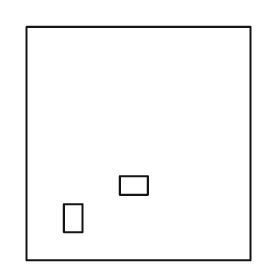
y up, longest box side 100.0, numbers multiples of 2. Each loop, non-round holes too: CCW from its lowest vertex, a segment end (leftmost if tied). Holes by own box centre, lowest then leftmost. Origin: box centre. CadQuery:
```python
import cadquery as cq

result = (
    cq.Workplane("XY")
    .moveTo(-48.0, -50.0)
    .lineTo(48.0, -50.0)
    .lineTo(48.0, 50.0)
    .lineTo(-48.0, 50.0)
    .close()
    .moveTo(-32.0, -38.0)
    .lineTo(-24.0, -38.0)
    .lineTo(-24.0, -26.0)
    .lineTo(-32.0, -26.0)
    .close()
    .moveTo(-8.0, -22.0)
    .lineTo(4.0, -22.0)
    .lineTo(4.0, -14.0)
    .lineTo(-8.0, -14.0)
    .close()
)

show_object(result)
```